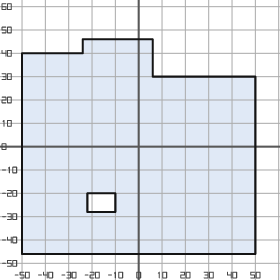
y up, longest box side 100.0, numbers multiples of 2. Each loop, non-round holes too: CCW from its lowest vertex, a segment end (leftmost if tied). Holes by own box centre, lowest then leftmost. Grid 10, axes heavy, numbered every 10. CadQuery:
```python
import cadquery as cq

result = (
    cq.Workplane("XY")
    .moveTo(-50.0, -46.0)
    .lineTo(50.0, -46.0)
    .lineTo(50.0, 30.0)
    .lineTo(6.0, 30.0)
    .lineTo(6.0, 46.0)
    .lineTo(-24.0, 46.0)
    .lineTo(-24.0, 40.0)
    .lineTo(-50.0, 40.0)
    .close()
    .moveTo(-22.0, -28.0)
    .lineTo(-10.0, -28.0)
    .lineTo(-10.0, -20.0)
    .lineTo(-22.0, -20.0)
    .close()
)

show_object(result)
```